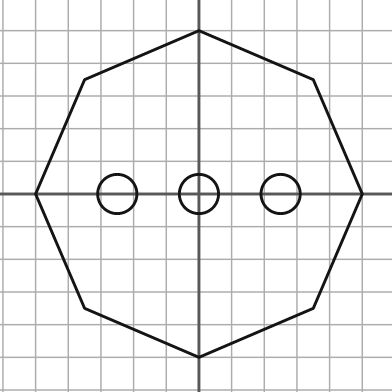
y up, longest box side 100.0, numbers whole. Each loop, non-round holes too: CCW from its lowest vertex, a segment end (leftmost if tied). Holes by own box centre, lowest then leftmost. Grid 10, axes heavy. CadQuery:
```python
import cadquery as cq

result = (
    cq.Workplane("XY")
    .moveTo(0.0, -50.0)
    .lineTo(35.0, -35.0)
    .lineTo(50.0, 0.0)
    .lineTo(35.0, 35.0)
    .lineTo(0.0, 50.0)
    .lineTo(-35.0, 35.0)
    .lineTo(-50.0, 0.0)
    .lineTo(-35.0, -35.0)
    .close()
    .moveTo(-25.0, 0.0)
    .circle(6.0)
    .moveTo(0.0, 0.0)
    .circle(6.0)
    .moveTo(25.0, 0.0)
    .circle(6.0)
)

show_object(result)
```